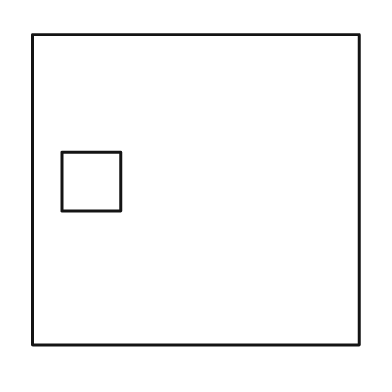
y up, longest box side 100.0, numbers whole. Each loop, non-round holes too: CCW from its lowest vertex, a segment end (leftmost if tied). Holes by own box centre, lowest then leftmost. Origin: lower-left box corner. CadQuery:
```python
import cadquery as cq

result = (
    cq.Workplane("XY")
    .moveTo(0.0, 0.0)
    .lineTo(100.0, 0.0)
    .lineTo(100.0, 95.0)
    .lineTo(0.0, 95.0)
    .close()
    .moveTo(9.0, 41.0)
    .lineTo(27.0, 41.0)
    .lineTo(27.0, 59.0)
    .lineTo(9.0, 59.0)
    .close()
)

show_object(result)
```